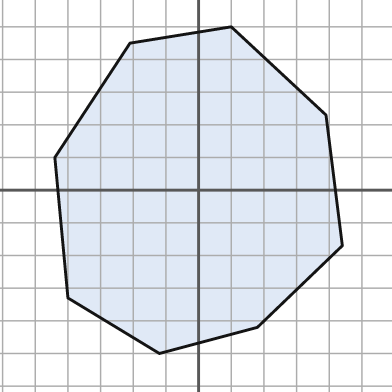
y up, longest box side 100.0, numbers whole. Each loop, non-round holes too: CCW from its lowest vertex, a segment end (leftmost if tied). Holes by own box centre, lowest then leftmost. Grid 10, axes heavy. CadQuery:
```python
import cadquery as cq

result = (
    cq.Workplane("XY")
    .moveTo(-12.0, -50.0)
    .lineTo(18.0, -42.0)
    .lineTo(44.0, -17.0)
    .lineTo(39.0, 23.0)
    .lineTo(10.0, 50.0)
    .lineTo(-21.0, 45.0)
    .lineTo(-44.0, 10.0)
    .lineTo(-40.0, -33.0)
    .close()
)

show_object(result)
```